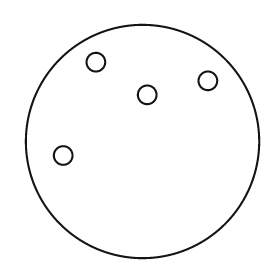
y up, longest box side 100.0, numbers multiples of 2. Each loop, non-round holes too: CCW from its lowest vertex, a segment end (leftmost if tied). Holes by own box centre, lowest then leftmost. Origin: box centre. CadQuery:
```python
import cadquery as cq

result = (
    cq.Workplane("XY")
    .moveTo(0.0, 0.0)
    .circle(50.0)
    .moveTo(-34.0, -6.0)
    .circle(4.0)
    .moveTo(2.0, 20.0)
    .circle(4.0)
    .moveTo(28.0, 26.0)
    .circle(4.0)
    .moveTo(-20.0, 34.0)
    .circle(4.0)
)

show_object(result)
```